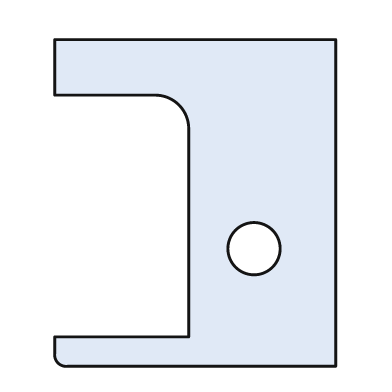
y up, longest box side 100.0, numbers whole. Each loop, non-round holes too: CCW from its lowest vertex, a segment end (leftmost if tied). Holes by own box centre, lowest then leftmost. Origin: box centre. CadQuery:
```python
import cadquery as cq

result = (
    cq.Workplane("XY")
    .moveTo(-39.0, -50.0)
    .lineTo(43.0, -50.0)
    .lineTo(43.0, 50.0)
    .lineTo(-43.0, 50.0)
    .lineTo(-43.0, 33.0)
    .lineTo(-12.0, 33.0)
    .threePointArc((-5.0, 30.0), (-2.0, 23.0))
    .lineTo(-2.0, -41.0)
    .lineTo(-43.0, -41.0)
    .lineTo(-43.0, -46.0)
    .threePointArc((-42.0, -49.0), (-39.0, -50.0))
    .close()
    .moveTo(18.0, -14.0)
    .circle(8.0)
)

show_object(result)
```